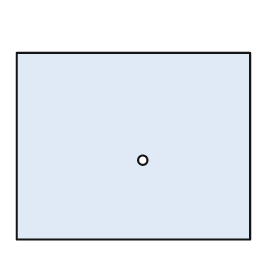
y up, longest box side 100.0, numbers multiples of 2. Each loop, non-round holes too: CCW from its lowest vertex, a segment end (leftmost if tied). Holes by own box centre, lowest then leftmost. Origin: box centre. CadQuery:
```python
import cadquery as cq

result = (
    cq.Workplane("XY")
    .moveTo(-50.0, -40.0)
    .lineTo(50.0, -40.0)
    .lineTo(50.0, 40.0)
    .lineTo(-50.0, 40.0)
    .close()
    .moveTo(4.0, -6.0)
    .circle(2.0)
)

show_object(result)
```